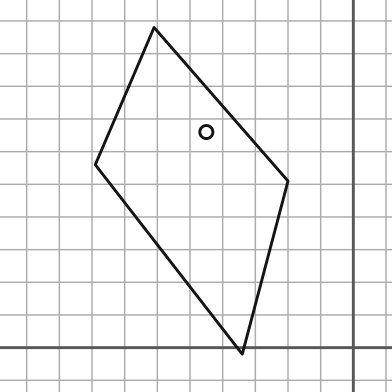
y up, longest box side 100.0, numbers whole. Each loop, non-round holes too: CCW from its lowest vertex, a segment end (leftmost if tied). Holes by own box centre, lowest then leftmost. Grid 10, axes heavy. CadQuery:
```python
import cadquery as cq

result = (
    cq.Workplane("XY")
    .moveTo(-34.0, -2.0)
    .lineTo(-20.0, 51.0)
    .lineTo(-61.0, 98.0)
    .lineTo(-79.0, 56.0)
    .close()
    .moveTo(-45.0, 66.0)
    .circle(2.0)
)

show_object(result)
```